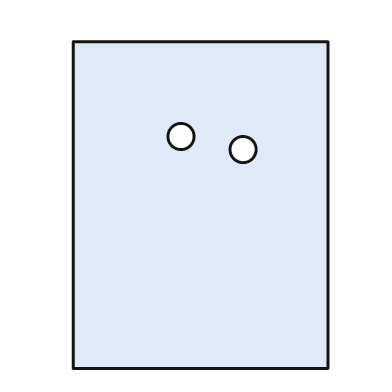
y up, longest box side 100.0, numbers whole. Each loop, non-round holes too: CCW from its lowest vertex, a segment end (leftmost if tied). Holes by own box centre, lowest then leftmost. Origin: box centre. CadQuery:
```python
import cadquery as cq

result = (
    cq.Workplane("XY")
    .moveTo(-39.0, -50.0)
    .lineTo(39.0, -50.0)
    .lineTo(39.0, 50.0)
    .lineTo(-39.0, 50.0)
    .close()
    .moveTo(13.0, 17.0)
    .circle(4.0)
    .moveTo(-6.0, 21.0)
    .circle(4.0)
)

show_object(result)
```